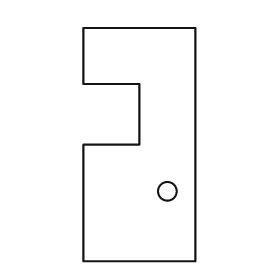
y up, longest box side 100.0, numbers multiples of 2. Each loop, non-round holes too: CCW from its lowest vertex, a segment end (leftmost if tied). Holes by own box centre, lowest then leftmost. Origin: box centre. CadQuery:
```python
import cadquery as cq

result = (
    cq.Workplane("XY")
    .moveTo(-24.0, -50.0)
    .lineTo(24.0, -50.0)
    .lineTo(24.0, 50.0)
    .lineTo(-24.0, 50.0)
    .lineTo(-24.0, 26.0)
    .lineTo(0.0, 26.0)
    .lineTo(0.0, 0.0)
    .lineTo(-24.0, 0.0)
    .close()
    .moveTo(12.0, -20.0)
    .circle(4.0)
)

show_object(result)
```